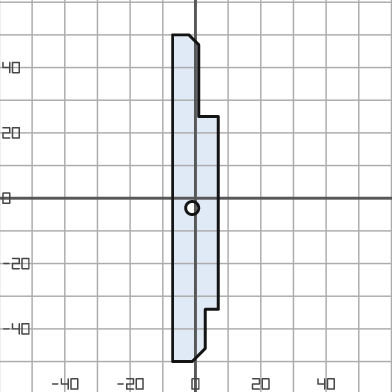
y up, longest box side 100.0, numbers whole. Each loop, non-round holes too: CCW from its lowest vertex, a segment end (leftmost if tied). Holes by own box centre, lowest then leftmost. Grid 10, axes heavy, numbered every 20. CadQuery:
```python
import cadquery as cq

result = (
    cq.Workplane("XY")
    .moveTo(-7.0, -50.0)
    .lineTo(-1.0, -50.0)
    .lineTo(3.0, -46.0)
    .lineTo(3.0, -34.0)
    .lineTo(7.0, -34.0)
    .lineTo(7.0, 25.0)
    .lineTo(1.0, 25.0)
    .lineTo(1.0, 47.0)
    .lineTo(-2.0, 50.0)
    .lineTo(-7.0, 50.0)
    .close()
    .moveTo(-1.0, -3.0)
    .circle(2.0)
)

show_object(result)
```